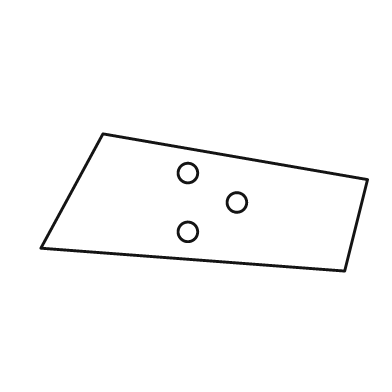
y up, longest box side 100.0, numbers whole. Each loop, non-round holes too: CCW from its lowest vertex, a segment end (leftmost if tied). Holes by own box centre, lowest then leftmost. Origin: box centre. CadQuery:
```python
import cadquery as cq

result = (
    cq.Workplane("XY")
    .moveTo(43.0, -21.0)
    .lineTo(50.0, 7.0)
    .lineTo(-31.0, 21.0)
    .lineTo(-50.0, -14.0)
    .close()
    .moveTo(-5.0, -9.0)
    .circle(3.0)
    .moveTo(10.0, 0.0)
    .circle(3.0)
    .moveTo(-5.0, 9.0)
    .circle(3.0)
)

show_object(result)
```